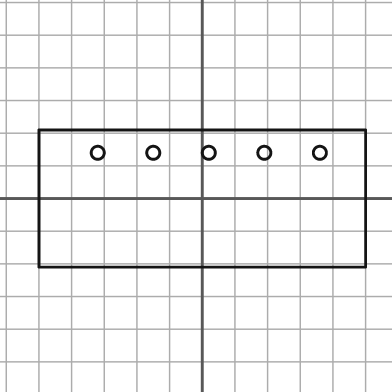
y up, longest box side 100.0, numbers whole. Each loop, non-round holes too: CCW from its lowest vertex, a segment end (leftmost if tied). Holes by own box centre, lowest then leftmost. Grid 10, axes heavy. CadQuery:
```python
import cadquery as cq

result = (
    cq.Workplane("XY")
    .moveTo(-50.0, -21.0)
    .lineTo(50.0, -21.0)
    .lineTo(50.0, 21.0)
    .lineTo(-50.0, 21.0)
    .close()
    .moveTo(-32.0, 14.0)
    .circle(2.0)
    .moveTo(-15.0, 14.0)
    .circle(2.0)
    .moveTo(2.0, 14.0)
    .circle(2.0)
    .moveTo(19.0, 14.0)
    .circle(2.0)
    .moveTo(36.0, 14.0)
    .circle(2.0)
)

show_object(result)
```